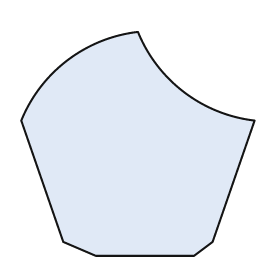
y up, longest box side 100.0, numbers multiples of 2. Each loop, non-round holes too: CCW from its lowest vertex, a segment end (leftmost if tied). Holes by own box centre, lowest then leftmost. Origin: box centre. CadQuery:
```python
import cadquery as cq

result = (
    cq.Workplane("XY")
    .moveTo(-18.0, -48.0)
    .lineTo(24.0, -48.0)
    .lineTo(32.0, -42.0)
    .lineTo(50.0, 10.0)
    .threePointArc((20.0, 22.0), (0.0, 48.0))
    .threePointArc((-30.0, 36.0), (-50.0, 10.0))
    .lineTo(-32.0, -42.0)
    .close()
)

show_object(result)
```